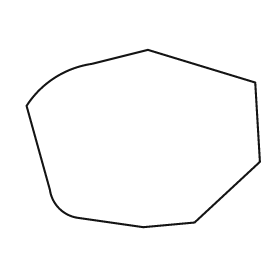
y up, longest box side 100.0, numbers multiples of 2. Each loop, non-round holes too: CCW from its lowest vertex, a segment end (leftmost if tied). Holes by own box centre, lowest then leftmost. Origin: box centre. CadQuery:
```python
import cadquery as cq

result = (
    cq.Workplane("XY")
    .moveTo(0.0, -38.0)
    .lineTo(22.0, -36.0)
    .lineTo(50.0, -10.0)
    .lineTo(48.0, 24.0)
    .lineTo(2.0, 38.0)
    .lineTo(-22.0, 32.0)
    .threePointArc((-38.0, 26.0), (-50.0, 14.0))
    .lineTo(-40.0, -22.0)
    .threePointArc((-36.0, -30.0), (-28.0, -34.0))
    .close()
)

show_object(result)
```